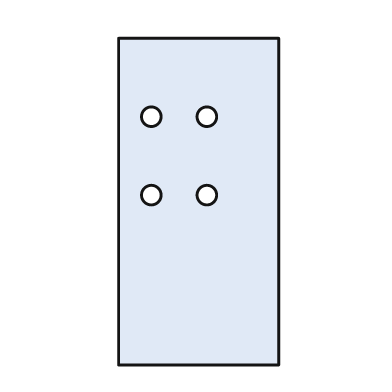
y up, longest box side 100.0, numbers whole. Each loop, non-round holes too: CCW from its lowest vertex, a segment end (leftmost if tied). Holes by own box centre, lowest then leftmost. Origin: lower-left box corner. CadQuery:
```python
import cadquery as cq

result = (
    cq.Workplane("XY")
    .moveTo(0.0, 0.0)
    .lineTo(49.0, 0.0)
    .lineTo(49.0, 100.0)
    .lineTo(0.0, 100.0)
    .close()
    .moveTo(10.0, 52.0)
    .circle(3.0)
    .moveTo(27.0, 52.0)
    .circle(3.0)
    .moveTo(10.0, 76.0)
    .circle(3.0)
    .moveTo(27.0, 76.0)
    .circle(3.0)
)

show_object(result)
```